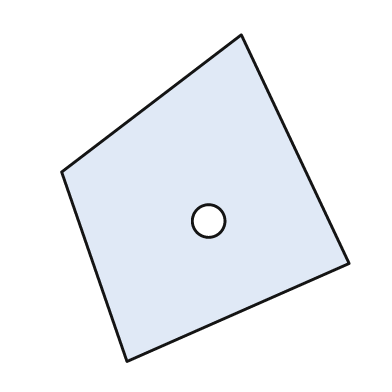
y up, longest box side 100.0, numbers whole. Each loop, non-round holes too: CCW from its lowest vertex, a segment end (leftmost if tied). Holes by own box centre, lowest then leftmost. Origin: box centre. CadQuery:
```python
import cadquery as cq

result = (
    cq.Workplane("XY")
    .moveTo(-24.0, -50.0)
    .lineTo(44.0, -20.0)
    .lineTo(11.0, 50.0)
    .lineTo(-44.0, 8.0)
    .close()
    .moveTo(1.0, -7.0)
    .circle(5.0)
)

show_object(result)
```